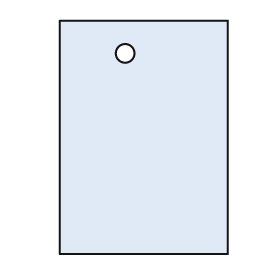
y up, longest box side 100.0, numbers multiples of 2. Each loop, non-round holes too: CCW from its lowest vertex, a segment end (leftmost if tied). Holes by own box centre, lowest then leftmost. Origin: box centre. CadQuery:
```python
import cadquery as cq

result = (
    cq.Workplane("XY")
    .moveTo(-36.0, -50.0)
    .lineTo(36.0, -50.0)
    .lineTo(36.0, 50.0)
    .lineTo(-36.0, 50.0)
    .close()
    .moveTo(-8.0, 36.0)
    .circle(4.0)
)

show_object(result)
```